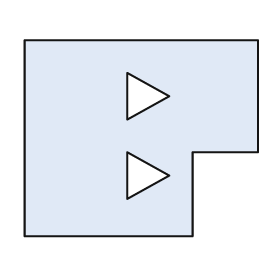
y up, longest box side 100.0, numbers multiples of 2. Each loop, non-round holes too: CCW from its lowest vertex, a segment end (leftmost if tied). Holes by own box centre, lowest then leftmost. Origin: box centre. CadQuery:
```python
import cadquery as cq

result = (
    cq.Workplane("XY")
    .moveTo(-50.0, -42.0)
    .lineTo(22.0, -42.0)
    .lineTo(22.0, -6.0)
    .lineTo(50.0, -6.0)
    .lineTo(50.0, 42.0)
    .lineTo(-50.0, 42.0)
    .close()
    .moveTo(-6.0, -26.0)
    .lineTo(12.0, -16.0)
    .lineTo(-6.0, -6.0)
    .close()
    .moveTo(-6.0, 8.0)
    .lineTo(12.0, 18.0)
    .lineTo(-6.0, 28.0)
    .close()
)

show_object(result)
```